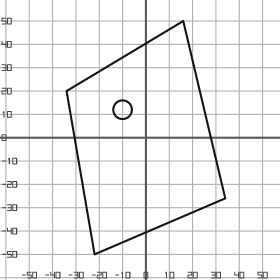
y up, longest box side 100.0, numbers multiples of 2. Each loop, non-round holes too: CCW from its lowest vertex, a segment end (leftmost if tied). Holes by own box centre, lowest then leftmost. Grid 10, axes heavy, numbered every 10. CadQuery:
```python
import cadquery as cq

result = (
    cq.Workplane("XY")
    .moveTo(-22.0, -50.0)
    .lineTo(34.0, -26.0)
    .lineTo(16.0, 50.0)
    .lineTo(-34.0, 20.0)
    .close()
    .moveTo(-10.0, 12.0)
    .circle(4.0)
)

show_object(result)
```